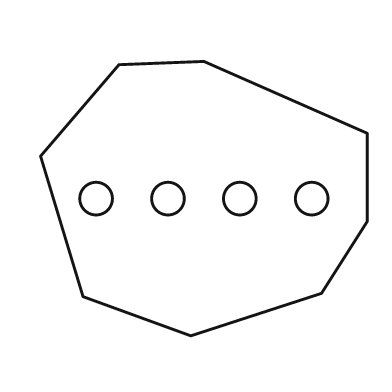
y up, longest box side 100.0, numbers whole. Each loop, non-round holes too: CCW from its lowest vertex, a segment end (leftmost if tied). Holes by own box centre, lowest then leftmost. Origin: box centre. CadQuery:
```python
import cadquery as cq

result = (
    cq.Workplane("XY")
    .moveTo(-4.0, -42.0)
    .lineTo(36.0, -29.0)
    .lineTo(50.0, -7.0)
    .lineTo(50.0, 20.0)
    .lineTo(0.0, 42.0)
    .lineTo(-26.0, 41.0)
    .lineTo(-50.0, 13.0)
    .lineTo(-37.0, -30.0)
    .close()
    .moveTo(-33.0, 0.0)
    .circle(5.0)
    .moveTo(-11.0, 0.0)
    .circle(5.0)
    .moveTo(11.0, 0.0)
    .circle(5.0)
    .moveTo(33.0, 0.0)
    .circle(5.0)
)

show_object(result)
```